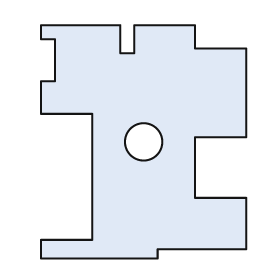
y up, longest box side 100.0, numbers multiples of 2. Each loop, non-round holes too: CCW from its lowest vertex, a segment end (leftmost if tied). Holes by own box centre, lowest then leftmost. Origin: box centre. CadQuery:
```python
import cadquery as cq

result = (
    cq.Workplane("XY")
    .moveTo(-44.0, -50.0)
    .lineTo(6.0, -50.0)
    .lineTo(6.0, -46.0)
    .lineTo(44.0, -46.0)
    .lineTo(44.0, -24.0)
    .lineTo(22.0, -24.0)
    .lineTo(22.0, 2.0)
    .lineTo(44.0, 2.0)
    .lineTo(44.0, 40.0)
    .lineTo(22.0, 40.0)
    .lineTo(22.0, 50.0)
    .lineTo(-4.0, 50.0)
    .lineTo(-4.0, 38.0)
    .lineTo(-10.0, 38.0)
    .lineTo(-10.0, 50.0)
    .lineTo(-44.0, 50.0)
    .lineTo(-44.0, 44.0)
    .lineTo(-38.0, 44.0)
    .lineTo(-38.0, 26.0)
    .lineTo(-44.0, 26.0)
    .lineTo(-44.0, 12.0)
    .lineTo(-22.0, 12.0)
    .lineTo(-22.0, -42.0)
    .lineTo(-44.0, -42.0)
    .close()
    .moveTo(0.0, 0.0)
    .circle(8.0)
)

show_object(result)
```